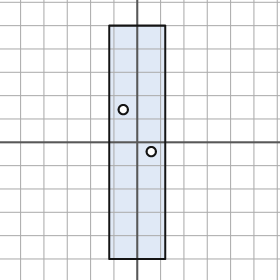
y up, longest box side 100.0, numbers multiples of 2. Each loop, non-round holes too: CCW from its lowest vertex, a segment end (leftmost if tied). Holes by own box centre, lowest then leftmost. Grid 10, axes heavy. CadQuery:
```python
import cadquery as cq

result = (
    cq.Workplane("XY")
    .moveTo(-12.0, -50.0)
    .lineTo(12.0, -50.0)
    .lineTo(12.0, 50.0)
    .lineTo(-12.0, 50.0)
    .close()
    .moveTo(6.0, -4.0)
    .circle(2.0)
    .moveTo(-6.0, 14.0)
    .circle(2.0)
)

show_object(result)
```